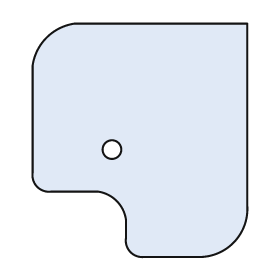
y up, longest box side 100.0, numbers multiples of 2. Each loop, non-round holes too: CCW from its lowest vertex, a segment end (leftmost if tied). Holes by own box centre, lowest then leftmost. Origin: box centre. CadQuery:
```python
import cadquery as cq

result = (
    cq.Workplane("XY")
    .moveTo(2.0, -50.0)
    .lineTo(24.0, -50.0)
    .threePointArc((40.0, -44.0), (46.0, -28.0))
    .lineTo(46.0, 50.0)
    .lineTo(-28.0, 50.0)
    .threePointArc((-40.0, 44.0), (-46.0, 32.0))
    .lineTo(-46.0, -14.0)
    .threePointArc((-44.0, -20.0), (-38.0, -22.0))
    .lineTo(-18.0, -22.0)
    .threePointArc((-10.0, -26.0), (-6.0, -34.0))
    .lineTo(-6.0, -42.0)
    .threePointArc((-4.0, -48.0), (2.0, -50.0))
    .close()
    .moveTo(-12.0, -4.0)
    .circle(4.0)
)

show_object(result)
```